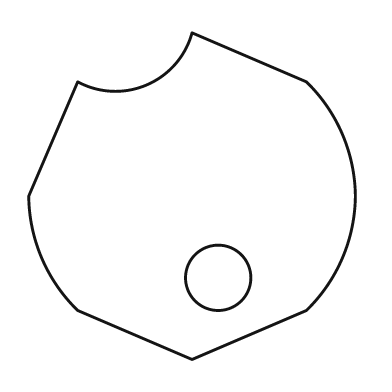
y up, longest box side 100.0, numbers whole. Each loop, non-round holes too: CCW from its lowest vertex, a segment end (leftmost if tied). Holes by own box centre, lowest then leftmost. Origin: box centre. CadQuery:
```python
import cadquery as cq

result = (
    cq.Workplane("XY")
    .moveTo(0.0, -50.0)
    .lineTo(35.0, -35.0)
    .threePointArc((46.0, -19.0), (50.0, 0.0))
    .threePointArc((46.0, 19.0), (35.0, 35.0))
    .lineTo(0.0, 50.0)
    .threePointArc((-14.0, 34.0), (-35.0, 35.0))
    .lineTo(-50.0, 0.0)
    .threePointArc((-46.0, -19.0), (-35.0, -35.0))
    .close()
    .moveTo(8.0, -25.0)
    .circle(10.0)
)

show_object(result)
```